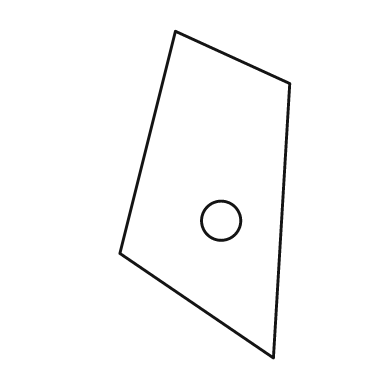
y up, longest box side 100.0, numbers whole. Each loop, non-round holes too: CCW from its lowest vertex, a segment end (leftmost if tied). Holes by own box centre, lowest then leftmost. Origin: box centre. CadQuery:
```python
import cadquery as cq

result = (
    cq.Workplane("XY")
    .moveTo(21.0, -50.0)
    .lineTo(26.0, 34.0)
    .lineTo(-9.0, 50.0)
    .lineTo(-26.0, -18.0)
    .close()
    .moveTo(5.0, -8.0)
    .circle(6.0)
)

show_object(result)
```